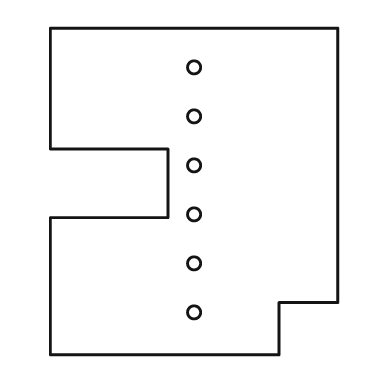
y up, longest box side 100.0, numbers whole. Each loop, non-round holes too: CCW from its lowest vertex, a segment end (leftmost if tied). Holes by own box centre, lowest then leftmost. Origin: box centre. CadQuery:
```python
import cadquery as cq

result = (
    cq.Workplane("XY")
    .moveTo(-44.0, -50.0)
    .lineTo(26.0, -50.0)
    .lineTo(26.0, -34.0)
    .lineTo(44.0, -34.0)
    .lineTo(44.0, 50.0)
    .lineTo(-44.0, 50.0)
    .lineTo(-44.0, 13.0)
    .lineTo(-8.0, 13.0)
    .lineTo(-8.0, -8.0)
    .lineTo(-44.0, -8.0)
    .close()
    .moveTo(0.0, -37.0)
    .circle(2.0)
    .moveTo(0.0, -22.0)
    .circle(2.0)
    .moveTo(0.0, -7.0)
    .circle(2.0)
    .moveTo(0.0, 8.0)
    .circle(2.0)
    .moveTo(0.0, 23.0)
    .circle(2.0)
    .moveTo(0.0, 38.0)
    .circle(2.0)
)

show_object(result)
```